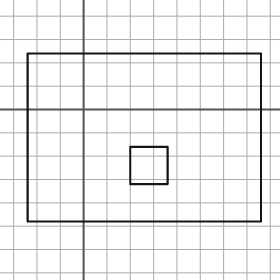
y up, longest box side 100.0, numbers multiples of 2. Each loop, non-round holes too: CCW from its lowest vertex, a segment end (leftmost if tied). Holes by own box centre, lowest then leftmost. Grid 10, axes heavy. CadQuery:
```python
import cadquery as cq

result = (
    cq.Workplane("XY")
    .moveTo(-24.0, -48.0)
    .lineTo(76.0, -48.0)
    .lineTo(76.0, 24.0)
    .lineTo(-24.0, 24.0)
    .close()
    .moveTo(20.0, -32.0)
    .lineTo(36.0, -32.0)
    .lineTo(36.0, -16.0)
    .lineTo(20.0, -16.0)
    .close()
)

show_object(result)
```